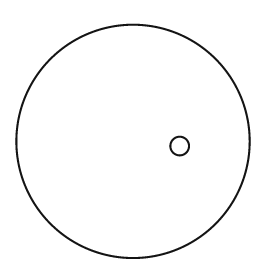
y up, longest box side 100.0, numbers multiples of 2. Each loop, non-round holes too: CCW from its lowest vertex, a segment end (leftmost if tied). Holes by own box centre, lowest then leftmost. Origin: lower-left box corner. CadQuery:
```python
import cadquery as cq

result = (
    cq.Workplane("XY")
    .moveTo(50.0, 50.0)
    .circle(50.0)
    .moveTo(70.0, 48.0)
    .circle(4.0)
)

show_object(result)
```